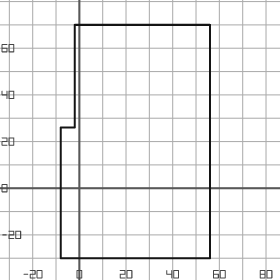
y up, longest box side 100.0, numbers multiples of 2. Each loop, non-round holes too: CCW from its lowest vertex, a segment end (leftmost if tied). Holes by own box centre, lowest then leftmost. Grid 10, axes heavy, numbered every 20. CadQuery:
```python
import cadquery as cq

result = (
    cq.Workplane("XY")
    .moveTo(-8.0, -30.0)
    .lineTo(56.0, -30.0)
    .lineTo(56.0, 70.0)
    .lineTo(-2.0, 70.0)
    .lineTo(-2.0, 26.0)
    .lineTo(-8.0, 26.0)
    .close()
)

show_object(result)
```